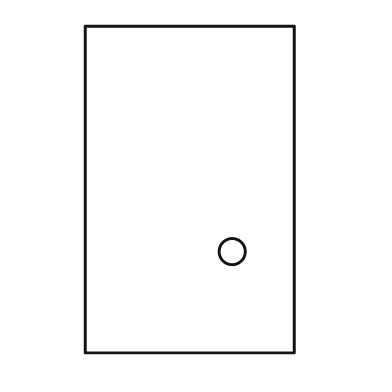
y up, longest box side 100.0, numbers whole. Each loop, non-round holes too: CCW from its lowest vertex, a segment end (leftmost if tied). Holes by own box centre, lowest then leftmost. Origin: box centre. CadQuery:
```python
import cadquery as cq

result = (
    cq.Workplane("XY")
    .moveTo(-32.0, -50.0)
    .lineTo(32.0, -50.0)
    .lineTo(32.0, 50.0)
    .lineTo(-32.0, 50.0)
    .close()
    .moveTo(13.0, -19.0)
    .circle(4.0)
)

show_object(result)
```